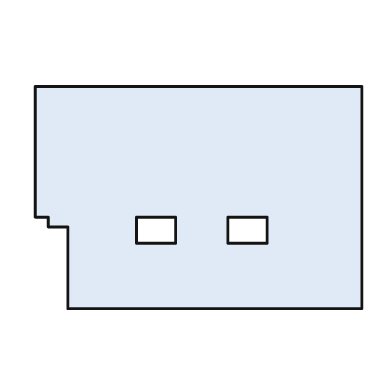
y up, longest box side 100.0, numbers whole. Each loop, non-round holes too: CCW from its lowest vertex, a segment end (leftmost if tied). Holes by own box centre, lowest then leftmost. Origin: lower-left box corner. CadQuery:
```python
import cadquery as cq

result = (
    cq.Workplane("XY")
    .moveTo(10.0, 0.0)
    .lineTo(100.0, 0.0)
    .lineTo(100.0, 68.0)
    .lineTo(0.0, 68.0)
    .lineTo(0.0, 28.0)
    .lineTo(4.0, 28.0)
    .lineTo(4.0, 25.0)
    .lineTo(10.0, 25.0)
    .close()
    .moveTo(31.0, 20.0)
    .lineTo(43.0, 20.0)
    .lineTo(43.0, 28.0)
    .lineTo(31.0, 28.0)
    .close()
    .moveTo(59.0, 20.0)
    .lineTo(71.0, 20.0)
    .lineTo(71.0, 28.0)
    .lineTo(59.0, 28.0)
    .close()
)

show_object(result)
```